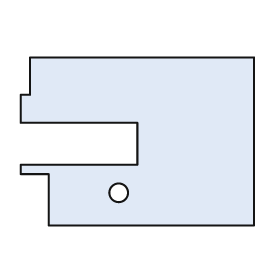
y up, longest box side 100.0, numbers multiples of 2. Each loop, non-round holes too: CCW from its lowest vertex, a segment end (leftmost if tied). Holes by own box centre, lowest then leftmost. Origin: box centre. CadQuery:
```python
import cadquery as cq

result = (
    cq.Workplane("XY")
    .moveTo(-38.0, -36.0)
    .lineTo(50.0, -36.0)
    .lineTo(50.0, 36.0)
    .lineTo(-46.0, 36.0)
    .lineTo(-46.0, 20.0)
    .lineTo(-50.0, 20.0)
    .lineTo(-50.0, 8.0)
    .lineTo(0.0, 8.0)
    .lineTo(0.0, -10.0)
    .lineTo(-50.0, -10.0)
    .lineTo(-50.0, -14.0)
    .lineTo(-38.0, -14.0)
    .close()
    .moveTo(-8.0, -22.0)
    .circle(4.0)
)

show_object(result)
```